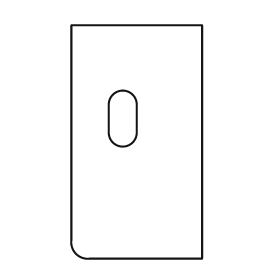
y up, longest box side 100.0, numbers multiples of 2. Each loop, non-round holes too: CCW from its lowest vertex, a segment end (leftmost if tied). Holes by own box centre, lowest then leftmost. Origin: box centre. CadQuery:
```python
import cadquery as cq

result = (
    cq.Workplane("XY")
    .moveTo(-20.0, -50.0)
    .lineTo(28.0, -50.0)
    .lineTo(28.0, 50.0)
    .lineTo(-28.0, 50.0)
    .lineTo(-28.0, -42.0)
    .threePointArc((-26.0, -48.0), (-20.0, -50.0))
    .close()
    .moveTo(-12.0, 4.0)
    .threePointArc((-6.0, -2.0), (0.0, 4.0))
    .lineTo(0.0, 16.0)
    .threePointArc((-6.0, 22.0), (-12.0, 16.0))
    .close()
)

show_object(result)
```